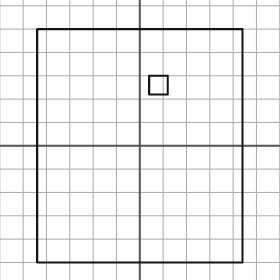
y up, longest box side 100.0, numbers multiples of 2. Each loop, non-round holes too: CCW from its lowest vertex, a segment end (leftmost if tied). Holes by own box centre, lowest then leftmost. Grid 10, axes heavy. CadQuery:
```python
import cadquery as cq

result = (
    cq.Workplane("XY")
    .moveTo(-44.0, -50.0)
    .lineTo(44.0, -50.0)
    .lineTo(44.0, 50.0)
    .lineTo(-44.0, 50.0)
    .close()
    .moveTo(4.0, 22.0)
    .lineTo(12.0, 22.0)
    .lineTo(12.0, 30.0)
    .lineTo(4.0, 30.0)
    .close()
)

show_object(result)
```